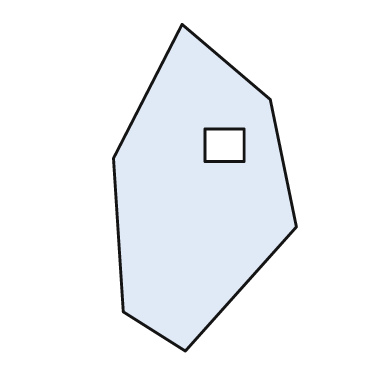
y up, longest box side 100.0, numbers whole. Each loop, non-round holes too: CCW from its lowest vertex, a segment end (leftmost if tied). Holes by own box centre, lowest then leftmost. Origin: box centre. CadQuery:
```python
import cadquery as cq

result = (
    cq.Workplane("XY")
    .moveTo(-6.0, -50.0)
    .lineTo(28.0, -12.0)
    .lineTo(20.0, 27.0)
    .lineTo(-7.0, 50.0)
    .lineTo(-28.0, 9.0)
    .lineTo(-25.0, -38.0)
    .close()
    .moveTo(0.0, 8.0)
    .lineTo(12.0, 8.0)
    .lineTo(12.0, 18.0)
    .lineTo(0.0, 18.0)
    .close()
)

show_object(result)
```